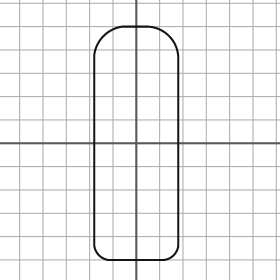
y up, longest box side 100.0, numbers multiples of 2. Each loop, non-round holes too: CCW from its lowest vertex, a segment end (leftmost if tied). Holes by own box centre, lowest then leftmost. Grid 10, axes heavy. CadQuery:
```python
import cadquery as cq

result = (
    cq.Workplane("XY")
    .moveTo(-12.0, -50.0)
    .lineTo(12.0, -50.0)
    .threePointArc((16.0, -48.0), (18.0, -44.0))
    .lineTo(18.0, 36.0)
    .threePointArc((14.0, 46.0), (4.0, 50.0))
    .lineTo(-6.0, 50.0)
    .threePointArc((-14.0, 46.0), (-18.0, 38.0))
    .lineTo(-18.0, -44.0)
    .threePointArc((-16.0, -48.0), (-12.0, -50.0))
    .close()
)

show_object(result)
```